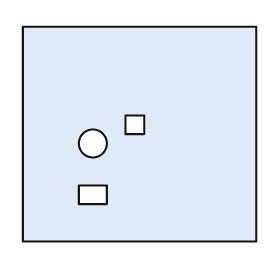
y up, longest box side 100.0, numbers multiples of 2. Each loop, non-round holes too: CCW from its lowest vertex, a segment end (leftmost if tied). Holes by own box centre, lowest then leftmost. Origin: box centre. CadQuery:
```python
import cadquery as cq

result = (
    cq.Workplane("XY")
    .moveTo(-50.0, -46.0)
    .lineTo(50.0, -46.0)
    .lineTo(50.0, 46.0)
    .lineTo(-50.0, 46.0)
    .close()
    .moveTo(-26.0, -30.0)
    .lineTo(-14.0, -30.0)
    .lineTo(-14.0, -22.0)
    .lineTo(-26.0, -22.0)
    .close()
    .moveTo(-20.0, -4.0)
    .circle(6.0)
    .moveTo(-6.0, 0.0)
    .lineTo(2.0, 0.0)
    .lineTo(2.0, 8.0)
    .lineTo(-6.0, 8.0)
    .close()
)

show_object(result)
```